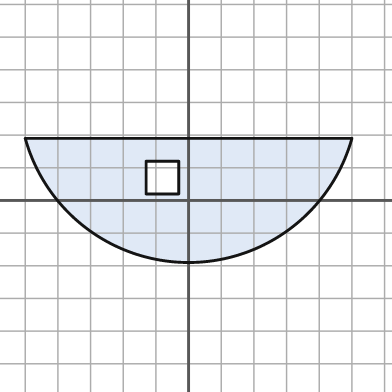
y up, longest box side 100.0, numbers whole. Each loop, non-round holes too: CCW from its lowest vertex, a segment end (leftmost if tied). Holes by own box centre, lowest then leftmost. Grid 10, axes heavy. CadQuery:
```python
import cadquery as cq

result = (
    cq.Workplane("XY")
    .moveTo(-50.0, 19.0)
    .threePointArc((0.0, -19.0), (50.0, 19.0))
    .close()
    .moveTo(-13.0, 2.0)
    .lineTo(-3.0, 2.0)
    .lineTo(-3.0, 12.0)
    .lineTo(-13.0, 12.0)
    .close()
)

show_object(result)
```